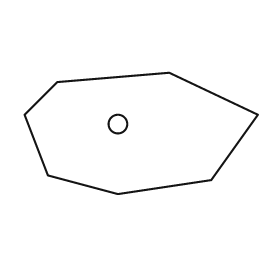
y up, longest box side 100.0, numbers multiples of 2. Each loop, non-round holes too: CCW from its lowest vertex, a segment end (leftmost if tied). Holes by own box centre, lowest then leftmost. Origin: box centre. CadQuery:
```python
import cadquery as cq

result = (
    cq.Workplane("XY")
    .moveTo(-10.0, -26.0)
    .lineTo(30.0, -20.0)
    .lineTo(50.0, 8.0)
    .lineTo(12.0, 26.0)
    .lineTo(-36.0, 22.0)
    .lineTo(-50.0, 8.0)
    .lineTo(-40.0, -18.0)
    .close()
    .moveTo(-10.0, 4.0)
    .circle(4.0)
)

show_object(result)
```